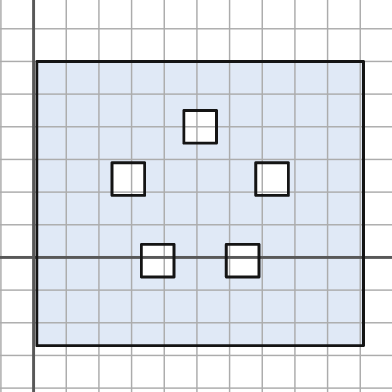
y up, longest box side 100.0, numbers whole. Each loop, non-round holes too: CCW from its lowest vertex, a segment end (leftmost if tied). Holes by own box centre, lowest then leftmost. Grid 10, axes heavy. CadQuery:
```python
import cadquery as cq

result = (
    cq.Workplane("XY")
    .moveTo(1.0, -27.0)
    .lineTo(101.0, -27.0)
    .lineTo(101.0, 60.0)
    .lineTo(1.0, 60.0)
    .close()
    .moveTo(33.0, -6.0)
    .lineTo(43.0, -6.0)
    .lineTo(43.0, 4.0)
    .lineTo(33.0, 4.0)
    .close()
    .moveTo(59.0, -6.0)
    .lineTo(69.0, -6.0)
    .lineTo(69.0, 4.0)
    .lineTo(59.0, 4.0)
    .close()
    .moveTo(24.0, 19.0)
    .lineTo(34.0, 19.0)
    .lineTo(34.0, 29.0)
    .lineTo(24.0, 29.0)
    .close()
    .moveTo(68.0, 19.0)
    .lineTo(78.0, 19.0)
    .lineTo(78.0, 29.0)
    .lineTo(68.0, 29.0)
    .close()
    .moveTo(46.0, 35.0)
    .lineTo(56.0, 35.0)
    .lineTo(56.0, 45.0)
    .lineTo(46.0, 45.0)
    .close()
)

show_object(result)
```